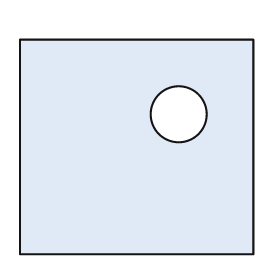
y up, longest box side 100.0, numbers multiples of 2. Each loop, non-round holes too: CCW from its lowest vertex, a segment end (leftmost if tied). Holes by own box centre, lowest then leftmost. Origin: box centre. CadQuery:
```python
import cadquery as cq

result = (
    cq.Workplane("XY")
    .moveTo(-50.0, -46.0)
    .lineTo(50.0, -46.0)
    .lineTo(50.0, 46.0)
    .lineTo(-50.0, 46.0)
    .close()
    .moveTo(18.0, 14.0)
    .circle(12.0)
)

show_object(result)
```